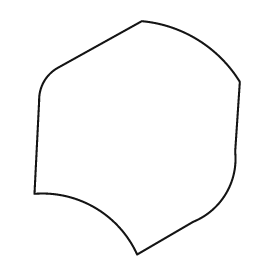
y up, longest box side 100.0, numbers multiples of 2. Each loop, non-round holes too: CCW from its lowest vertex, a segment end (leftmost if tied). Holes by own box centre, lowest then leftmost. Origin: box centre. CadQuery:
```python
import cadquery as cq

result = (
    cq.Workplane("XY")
    .moveTo(0.0, -50.0)
    .lineTo(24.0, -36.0)
    .threePointArc((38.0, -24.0), (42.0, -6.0))
    .lineTo(44.0, 24.0)
    .threePointArc((26.0, 42.0), (2.0, 50.0))
    .lineTo(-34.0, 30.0)
    .threePointArc((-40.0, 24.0), (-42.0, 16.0))
    .lineTo(-44.0, -24.0)
    .threePointArc((-18.0, -30.0), (0.0, -50.0))
    .close()
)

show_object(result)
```